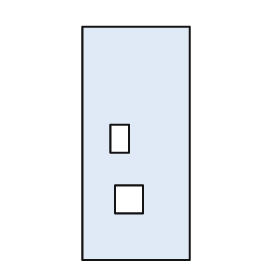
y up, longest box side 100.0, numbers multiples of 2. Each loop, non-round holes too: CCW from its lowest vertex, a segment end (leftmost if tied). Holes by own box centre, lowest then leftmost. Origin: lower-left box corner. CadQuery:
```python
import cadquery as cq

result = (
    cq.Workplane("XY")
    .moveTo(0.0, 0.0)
    .lineTo(46.0, 0.0)
    .lineTo(46.0, 100.0)
    .lineTo(0.0, 100.0)
    .close()
    .moveTo(14.0, 20.0)
    .lineTo(26.0, 20.0)
    .lineTo(26.0, 32.0)
    .lineTo(14.0, 32.0)
    .close()
    .moveTo(12.0, 46.0)
    .lineTo(20.0, 46.0)
    .lineTo(20.0, 58.0)
    .lineTo(12.0, 58.0)
    .close()
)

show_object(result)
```